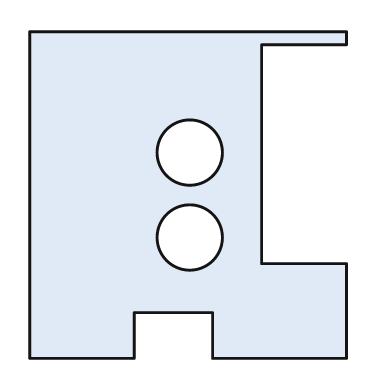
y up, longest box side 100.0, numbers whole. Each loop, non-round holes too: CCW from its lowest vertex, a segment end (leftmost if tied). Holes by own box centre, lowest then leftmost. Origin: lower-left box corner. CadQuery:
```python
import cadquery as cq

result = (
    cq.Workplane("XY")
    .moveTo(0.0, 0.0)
    .lineTo(32.0, 0.0)
    .lineTo(32.0, 14.0)
    .lineTo(56.0, 14.0)
    .lineTo(56.0, 0.0)
    .lineTo(97.0, 0.0)
    .lineTo(97.0, 29.0)
    .lineTo(71.0, 29.0)
    .lineTo(71.0, 96.0)
    .lineTo(97.0, 96.0)
    .lineTo(97.0, 100.0)
    .lineTo(0.0, 100.0)
    .close()
    .moveTo(49.0, 37.0)
    .circle(10.0)
    .moveTo(49.0, 63.0)
    .circle(10.0)
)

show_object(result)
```